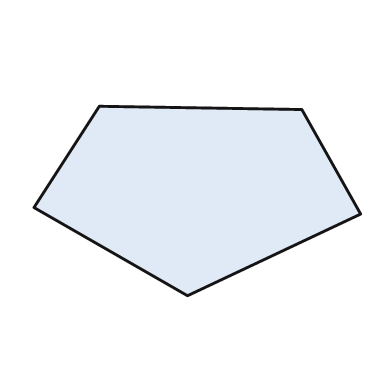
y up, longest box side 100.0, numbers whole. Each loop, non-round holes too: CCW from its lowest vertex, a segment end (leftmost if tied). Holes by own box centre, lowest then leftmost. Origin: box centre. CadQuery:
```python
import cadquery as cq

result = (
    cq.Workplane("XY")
    .moveTo(-3.0, -29.0)
    .lineTo(50.0, -4.0)
    .lineTo(32.0, 28.0)
    .lineTo(-30.0, 29.0)
    .lineTo(-50.0, -2.0)
    .close()
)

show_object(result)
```